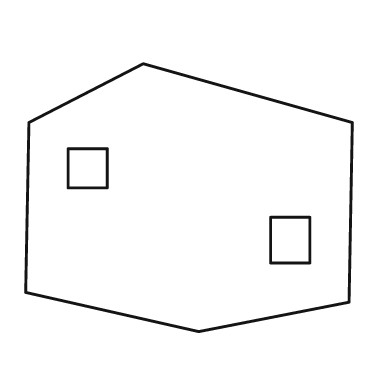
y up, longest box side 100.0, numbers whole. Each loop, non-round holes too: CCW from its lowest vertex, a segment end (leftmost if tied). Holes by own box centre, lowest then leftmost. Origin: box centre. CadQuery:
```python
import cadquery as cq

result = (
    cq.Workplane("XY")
    .moveTo(3.0, -41.0)
    .lineTo(49.0, -32.0)
    .lineTo(50.0, 23.0)
    .lineTo(-14.0, 41.0)
    .lineTo(-49.0, 23.0)
    .lineTo(-50.0, -29.0)
    .close()
    .moveTo(25.0, -20.0)
    .lineTo(37.0, -20.0)
    .lineTo(37.0, -6.0)
    .lineTo(25.0, -6.0)
    .close()
    .moveTo(-37.0, 3.0)
    .lineTo(-25.0, 3.0)
    .lineTo(-25.0, 15.0)
    .lineTo(-37.0, 15.0)
    .close()
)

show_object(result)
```